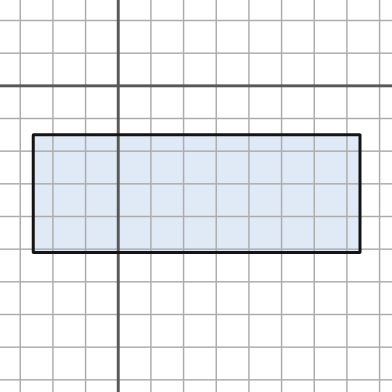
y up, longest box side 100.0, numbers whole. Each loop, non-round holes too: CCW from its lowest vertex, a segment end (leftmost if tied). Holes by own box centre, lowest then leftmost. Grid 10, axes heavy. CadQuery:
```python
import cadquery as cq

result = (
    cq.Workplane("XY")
    .moveTo(-26.0, -51.0)
    .lineTo(74.0, -51.0)
    .lineTo(74.0, -15.0)
    .lineTo(-26.0, -15.0)
    .close()
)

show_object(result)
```